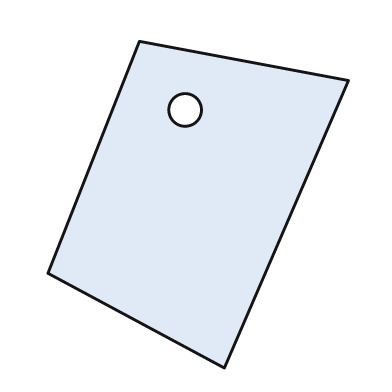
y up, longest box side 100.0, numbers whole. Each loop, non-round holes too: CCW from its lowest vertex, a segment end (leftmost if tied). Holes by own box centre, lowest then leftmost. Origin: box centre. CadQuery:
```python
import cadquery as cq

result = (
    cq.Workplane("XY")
    .moveTo(8.0, -50.0)
    .lineTo(46.0, 38.0)
    .lineTo(-18.0, 50.0)
    .lineTo(-46.0, -21.0)
    .close()
    .moveTo(-4.0, 29.0)
    .circle(5.0)
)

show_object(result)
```